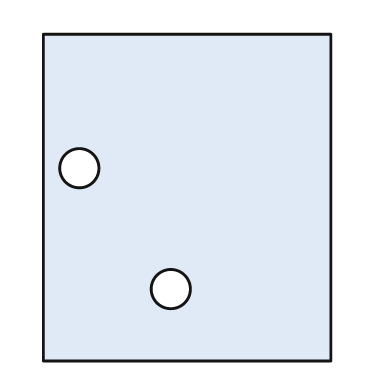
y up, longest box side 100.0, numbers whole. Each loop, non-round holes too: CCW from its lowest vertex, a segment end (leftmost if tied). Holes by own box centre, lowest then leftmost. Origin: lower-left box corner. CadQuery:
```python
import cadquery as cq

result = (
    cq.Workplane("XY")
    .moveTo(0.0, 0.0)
    .lineTo(88.0, 0.0)
    .lineTo(88.0, 100.0)
    .lineTo(0.0, 100.0)
    .close()
    .moveTo(39.0, 22.0)
    .circle(6.0)
    .moveTo(11.0, 59.0)
    .circle(6.0)
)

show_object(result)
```